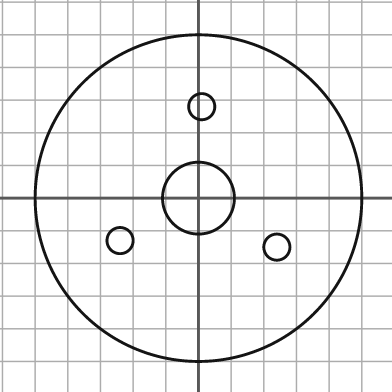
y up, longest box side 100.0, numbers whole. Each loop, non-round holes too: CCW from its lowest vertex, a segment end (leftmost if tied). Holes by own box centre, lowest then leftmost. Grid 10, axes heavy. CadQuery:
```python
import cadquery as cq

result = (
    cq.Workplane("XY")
    .moveTo(0.0, 0.0)
    .circle(50.0)
    .moveTo(24.0, -15.0)
    .circle(4.0)
    .moveTo(-24.0, -13.0)
    .circle(4.0)
    .moveTo(0.0, 0.0)
    .circle(11.0)
    .moveTo(1.0, 28.0)
    .circle(4.0)
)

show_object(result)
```